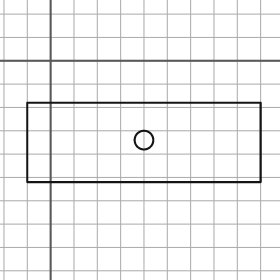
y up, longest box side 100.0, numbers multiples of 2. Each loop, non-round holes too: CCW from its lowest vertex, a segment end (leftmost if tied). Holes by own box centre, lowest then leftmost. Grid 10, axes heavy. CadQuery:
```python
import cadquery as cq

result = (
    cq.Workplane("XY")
    .moveTo(-10.0, -52.0)
    .lineTo(90.0, -52.0)
    .lineTo(90.0, -18.0)
    .lineTo(-10.0, -18.0)
    .close()
    .moveTo(40.0, -34.0)
    .circle(4.0)
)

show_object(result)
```